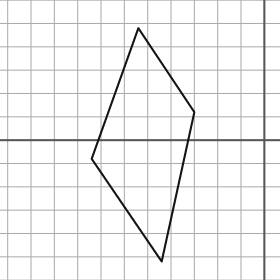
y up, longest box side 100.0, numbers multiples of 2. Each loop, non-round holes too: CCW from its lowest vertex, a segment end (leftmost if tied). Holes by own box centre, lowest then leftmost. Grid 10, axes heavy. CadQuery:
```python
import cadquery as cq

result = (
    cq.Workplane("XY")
    .moveTo(-44.0, -52.0)
    .lineTo(-30.0, 12.0)
    .lineTo(-54.0, 48.0)
    .lineTo(-74.0, -8.0)
    .close()
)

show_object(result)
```